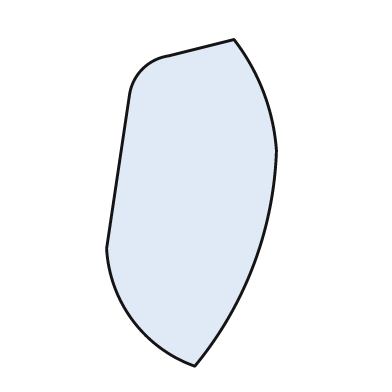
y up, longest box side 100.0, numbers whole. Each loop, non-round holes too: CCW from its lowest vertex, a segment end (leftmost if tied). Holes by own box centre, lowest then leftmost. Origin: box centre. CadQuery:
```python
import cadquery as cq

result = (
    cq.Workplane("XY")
    .moveTo(1.0, -50.0)
    .threePointArc((19.0, -19.0), (26.0, 16.0))
    .threePointArc((22.0, 34.0), (13.0, 50.0))
    .lineTo(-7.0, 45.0)
    .threePointArc((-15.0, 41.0), (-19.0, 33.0))
    .lineTo(-26.0, -14.0)
    .threePointArc((-18.0, -36.0), (1.0, -50.0))
    .close()
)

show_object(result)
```